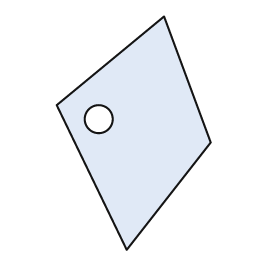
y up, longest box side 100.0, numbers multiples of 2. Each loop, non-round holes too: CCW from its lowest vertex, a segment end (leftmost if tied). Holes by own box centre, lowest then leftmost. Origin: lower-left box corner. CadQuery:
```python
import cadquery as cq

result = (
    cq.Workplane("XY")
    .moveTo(30.0, 0.0)
    .lineTo(66.0, 46.0)
    .lineTo(46.0, 100.0)
    .lineTo(0.0, 62.0)
    .close()
    .moveTo(18.0, 56.0)
    .circle(6.0)
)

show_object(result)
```